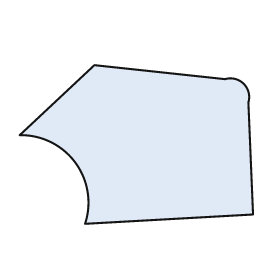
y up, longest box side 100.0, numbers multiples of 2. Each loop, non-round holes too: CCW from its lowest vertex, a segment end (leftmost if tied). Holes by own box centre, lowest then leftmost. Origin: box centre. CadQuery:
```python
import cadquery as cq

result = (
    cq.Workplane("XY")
    .moveTo(-22.0, -34.0)
    .lineTo(50.0, -30.0)
    .lineTo(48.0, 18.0)
    .threePointArc((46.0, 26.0), (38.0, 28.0))
    .lineTo(-18.0, 34.0)
    .lineTo(-50.0, 4.0)
    .threePointArc((-26.0, -8.0), (-22.0, -34.0))
    .close()
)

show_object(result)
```